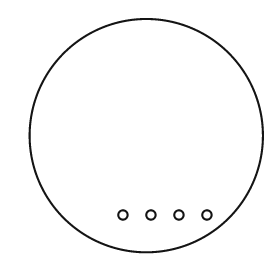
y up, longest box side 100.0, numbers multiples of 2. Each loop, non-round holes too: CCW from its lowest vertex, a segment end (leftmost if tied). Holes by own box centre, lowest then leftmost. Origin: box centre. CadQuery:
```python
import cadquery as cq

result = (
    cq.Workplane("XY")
    .moveTo(0.0, 0.0)
    .circle(50.0)
    .moveTo(-10.0, -34.0)
    .circle(2.0)
    .moveTo(2.0, -34.0)
    .circle(2.0)
    .moveTo(14.0, -34.0)
    .circle(2.0)
    .moveTo(26.0, -34.0)
    .circle(2.0)
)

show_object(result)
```